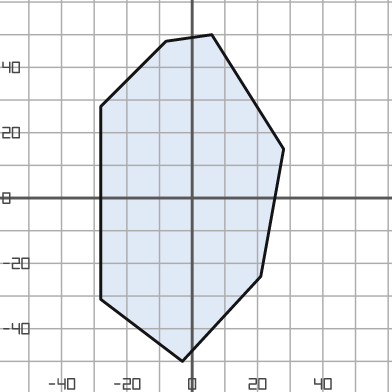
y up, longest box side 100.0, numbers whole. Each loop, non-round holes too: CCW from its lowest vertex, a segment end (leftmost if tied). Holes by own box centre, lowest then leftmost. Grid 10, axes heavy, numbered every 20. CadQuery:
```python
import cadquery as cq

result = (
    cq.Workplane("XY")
    .moveTo(-3.0, -50.0)
    .lineTo(21.0, -24.0)
    .lineTo(28.0, 15.0)
    .lineTo(6.0, 50.0)
    .lineTo(-8.0, 48.0)
    .lineTo(-28.0, 28.0)
    .lineTo(-28.0, -31.0)
    .close()
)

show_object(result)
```